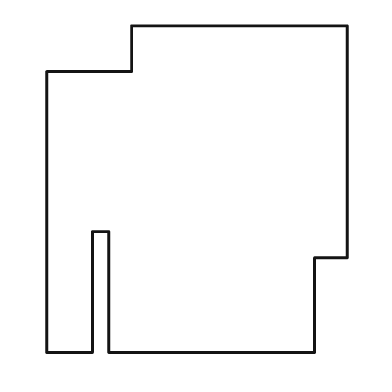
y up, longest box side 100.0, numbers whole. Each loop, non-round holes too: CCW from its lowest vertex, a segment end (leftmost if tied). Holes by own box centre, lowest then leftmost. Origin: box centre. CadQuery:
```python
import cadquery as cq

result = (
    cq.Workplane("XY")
    .moveTo(-46.0, -50.0)
    .lineTo(-32.0, -50.0)
    .lineTo(-32.0, -13.0)
    .lineTo(-27.0, -13.0)
    .lineTo(-27.0, -50.0)
    .lineTo(36.0, -50.0)
    .lineTo(36.0, -21.0)
    .lineTo(46.0, -21.0)
    .lineTo(46.0, 50.0)
    .lineTo(-20.0, 50.0)
    .lineTo(-20.0, 36.0)
    .lineTo(-46.0, 36.0)
    .close()
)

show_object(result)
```